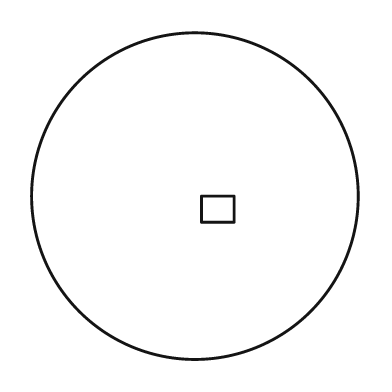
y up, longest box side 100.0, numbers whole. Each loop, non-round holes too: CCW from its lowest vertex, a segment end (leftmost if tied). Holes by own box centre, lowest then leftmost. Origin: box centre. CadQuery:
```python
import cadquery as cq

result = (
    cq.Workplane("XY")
    .moveTo(0.0, 0.0)
    .circle(50.0)
    .moveTo(2.0, -8.0)
    .lineTo(12.0, -8.0)
    .lineTo(12.0, 0.0)
    .lineTo(2.0, 0.0)
    .close()
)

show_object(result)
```